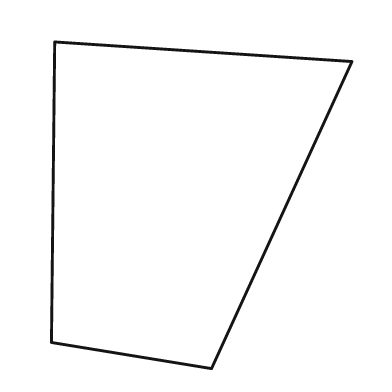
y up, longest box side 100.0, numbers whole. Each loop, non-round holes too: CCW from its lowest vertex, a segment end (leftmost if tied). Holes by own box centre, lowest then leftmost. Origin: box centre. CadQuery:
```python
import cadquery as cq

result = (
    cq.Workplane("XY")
    .moveTo(3.0, -50.0)
    .lineTo(46.0, 44.0)
    .lineTo(-45.0, 50.0)
    .lineTo(-46.0, -42.0)
    .close()
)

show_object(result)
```